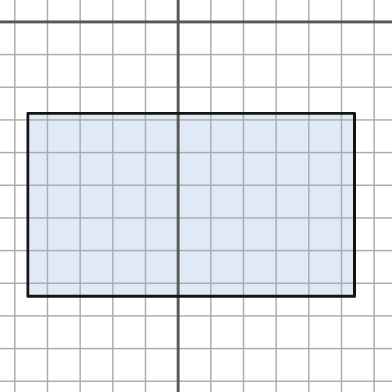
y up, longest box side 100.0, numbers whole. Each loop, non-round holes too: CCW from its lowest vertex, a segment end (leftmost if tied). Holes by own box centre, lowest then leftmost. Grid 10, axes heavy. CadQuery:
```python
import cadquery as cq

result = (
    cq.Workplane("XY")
    .moveTo(-46.0, -84.0)
    .lineTo(54.0, -84.0)
    .lineTo(54.0, -28.0)
    .lineTo(-46.0, -28.0)
    .close()
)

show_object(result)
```